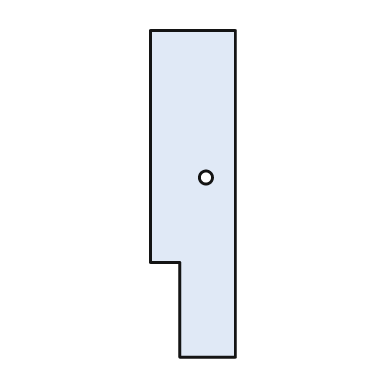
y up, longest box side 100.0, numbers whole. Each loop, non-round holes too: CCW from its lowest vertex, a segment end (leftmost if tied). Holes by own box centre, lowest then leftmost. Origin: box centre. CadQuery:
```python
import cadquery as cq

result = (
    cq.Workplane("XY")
    .moveTo(-4.0, -50.0)
    .lineTo(13.0, -50.0)
    .lineTo(13.0, 50.0)
    .lineTo(-13.0, 50.0)
    .lineTo(-13.0, -21.0)
    .lineTo(-4.0, -21.0)
    .close()
    .moveTo(4.0, 5.0)
    .circle(2.0)
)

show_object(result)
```